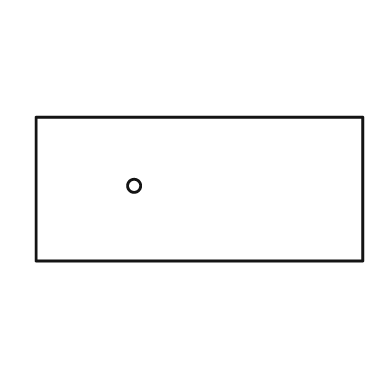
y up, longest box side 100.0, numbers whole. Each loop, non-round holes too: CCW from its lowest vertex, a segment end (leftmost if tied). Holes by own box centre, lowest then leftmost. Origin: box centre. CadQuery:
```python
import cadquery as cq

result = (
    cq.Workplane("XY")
    .moveTo(-50.0, -22.0)
    .lineTo(50.0, -22.0)
    .lineTo(50.0, 22.0)
    .lineTo(-50.0, 22.0)
    .close()
    .moveTo(-20.0, 1.0)
    .circle(2.0)
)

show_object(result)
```